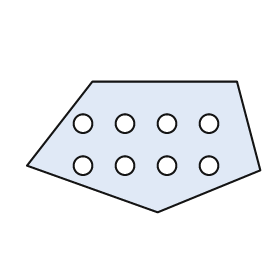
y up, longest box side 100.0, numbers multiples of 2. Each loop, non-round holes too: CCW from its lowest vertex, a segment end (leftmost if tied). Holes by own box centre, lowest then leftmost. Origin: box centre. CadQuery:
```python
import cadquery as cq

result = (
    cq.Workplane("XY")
    .moveTo(6.0, -28.0)
    .lineTo(50.0, -10.0)
    .lineTo(40.0, 28.0)
    .lineTo(-22.0, 28.0)
    .lineTo(-50.0, -8.0)
    .close()
    .moveTo(-26.0, -8.0)
    .circle(4.0)
    .moveTo(-8.0, -8.0)
    .circle(4.0)
    .moveTo(10.0, -8.0)
    .circle(4.0)
    .moveTo(28.0, -8.0)
    .circle(4.0)
    .moveTo(-26.0, 10.0)
    .circle(4.0)
    .moveTo(-8.0, 10.0)
    .circle(4.0)
    .moveTo(10.0, 10.0)
    .circle(4.0)
    .moveTo(28.0, 10.0)
    .circle(4.0)
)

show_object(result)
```